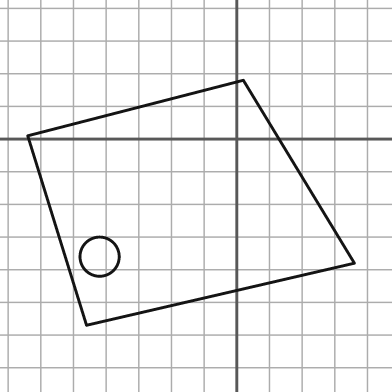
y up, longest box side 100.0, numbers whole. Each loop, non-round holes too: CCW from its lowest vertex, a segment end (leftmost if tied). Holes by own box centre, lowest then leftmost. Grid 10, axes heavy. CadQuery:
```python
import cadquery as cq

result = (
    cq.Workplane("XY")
    .moveTo(-46.0, -57.0)
    .lineTo(36.0, -38.0)
    .lineTo(2.0, 18.0)
    .lineTo(-64.0, 1.0)
    .close()
    .moveTo(-42.0, -36.0)
    .circle(6.0)
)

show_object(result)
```